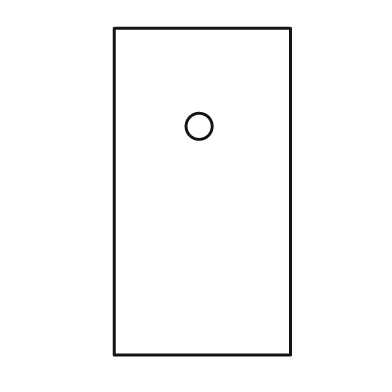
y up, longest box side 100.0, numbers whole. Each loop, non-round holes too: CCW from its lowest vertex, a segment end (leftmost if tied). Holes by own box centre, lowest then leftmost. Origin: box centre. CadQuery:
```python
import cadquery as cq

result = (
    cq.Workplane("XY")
    .moveTo(-27.0, -50.0)
    .lineTo(27.0, -50.0)
    .lineTo(27.0, 50.0)
    .lineTo(-27.0, 50.0)
    .close()
    .moveTo(-1.0, 20.0)
    .circle(4.0)
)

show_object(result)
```